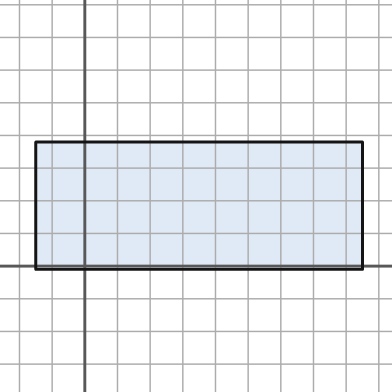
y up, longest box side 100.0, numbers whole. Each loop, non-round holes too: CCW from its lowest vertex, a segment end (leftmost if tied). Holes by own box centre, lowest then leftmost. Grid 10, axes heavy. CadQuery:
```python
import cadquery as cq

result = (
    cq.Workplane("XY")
    .moveTo(-15.0, -1.0)
    .lineTo(85.0, -1.0)
    .lineTo(85.0, 38.0)
    .lineTo(-15.0, 38.0)
    .close()
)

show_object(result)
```